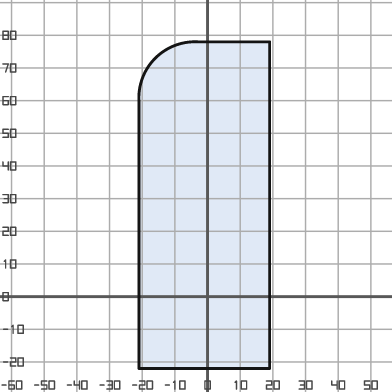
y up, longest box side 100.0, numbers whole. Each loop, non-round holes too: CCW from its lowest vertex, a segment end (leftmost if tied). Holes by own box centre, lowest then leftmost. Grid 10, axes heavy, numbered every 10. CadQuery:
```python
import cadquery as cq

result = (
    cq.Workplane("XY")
    .moveTo(-21.0, -22.0)
    .lineTo(19.0, -22.0)
    .lineTo(19.0, 78.0)
    .lineTo(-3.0, 78.0)
    .threePointArc((-16.0, 73.0), (-21.0, 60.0))
    .close()
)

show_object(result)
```